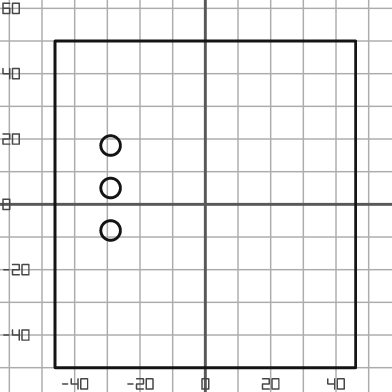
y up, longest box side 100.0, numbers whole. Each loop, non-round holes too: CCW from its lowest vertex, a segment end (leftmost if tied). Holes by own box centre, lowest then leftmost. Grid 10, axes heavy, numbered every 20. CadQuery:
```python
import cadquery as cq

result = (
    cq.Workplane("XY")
    .moveTo(-46.0, -50.0)
    .lineTo(46.0, -50.0)
    .lineTo(46.0, 50.0)
    .lineTo(-46.0, 50.0)
    .close()
    .moveTo(-29.0, -8.0)
    .circle(3.0)
    .moveTo(-29.0, 5.0)
    .circle(3.0)
    .moveTo(-29.0, 18.0)
    .circle(3.0)
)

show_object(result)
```